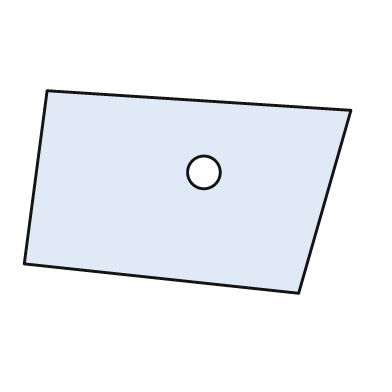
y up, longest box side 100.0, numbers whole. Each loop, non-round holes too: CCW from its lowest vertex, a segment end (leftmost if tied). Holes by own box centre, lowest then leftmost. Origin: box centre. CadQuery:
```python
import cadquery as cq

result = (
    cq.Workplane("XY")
    .moveTo(34.0, -31.0)
    .lineTo(50.0, 25.0)
    .lineTo(-43.0, 31.0)
    .lineTo(-50.0, -22.0)
    .close()
    .moveTo(5.0, 6.0)
    .circle(5.0)
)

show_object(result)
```